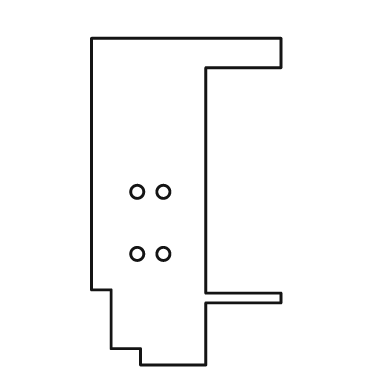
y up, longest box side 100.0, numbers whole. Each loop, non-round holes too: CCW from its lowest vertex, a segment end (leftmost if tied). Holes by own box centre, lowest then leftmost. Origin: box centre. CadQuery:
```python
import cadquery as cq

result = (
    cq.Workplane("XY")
    .moveTo(-14.0, -50.0)
    .lineTo(6.0, -50.0)
    .lineTo(6.0, -31.0)
    .lineTo(29.0, -31.0)
    .lineTo(29.0, -28.0)
    .lineTo(6.0, -28.0)
    .lineTo(6.0, 41.0)
    .lineTo(29.0, 41.0)
    .lineTo(29.0, 50.0)
    .lineTo(-29.0, 50.0)
    .lineTo(-29.0, -27.0)
    .lineTo(-23.0, -27.0)
    .lineTo(-23.0, -45.0)
    .lineTo(-14.0, -45.0)
    .close()
    .moveTo(-15.0, -16.0)
    .circle(2.0)
    .moveTo(-7.0, -16.0)
    .circle(2.0)
    .moveTo(-15.0, 3.0)
    .circle(2.0)
    .moveTo(-7.0, 3.0)
    .circle(2.0)
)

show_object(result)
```